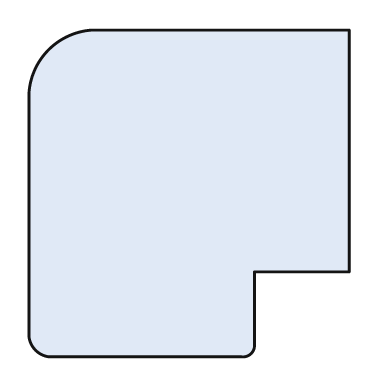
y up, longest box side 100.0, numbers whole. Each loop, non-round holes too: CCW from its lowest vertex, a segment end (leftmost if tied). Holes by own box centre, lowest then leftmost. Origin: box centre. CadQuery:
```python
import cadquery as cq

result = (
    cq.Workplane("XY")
    .moveTo(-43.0, -50.0)
    .lineTo(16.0, -50.0)
    .threePointArc((19.0, -49.0), (20.0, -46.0))
    .lineTo(20.0, -24.0)
    .lineTo(49.0, -24.0)
    .lineTo(49.0, 50.0)
    .lineTo(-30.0, 50.0)
    .threePointArc((-43.0, 44.0), (-49.0, 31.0))
    .lineTo(-49.0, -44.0)
    .threePointArc((-47.0, -48.0), (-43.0, -50.0))
    .close()
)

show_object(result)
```